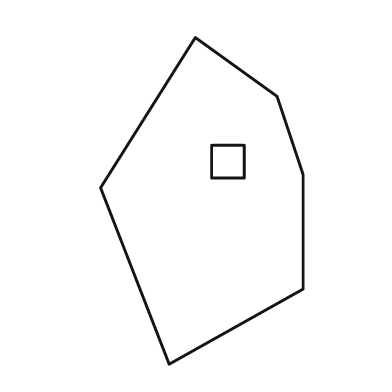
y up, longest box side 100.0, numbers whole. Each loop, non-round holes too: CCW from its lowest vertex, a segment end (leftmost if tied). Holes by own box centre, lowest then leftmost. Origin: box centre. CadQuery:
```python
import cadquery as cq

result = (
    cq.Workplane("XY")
    .moveTo(-10.0, -50.0)
    .lineTo(31.0, -27.0)
    .lineTo(31.0, 8.0)
    .lineTo(23.0, 32.0)
    .lineTo(-2.0, 50.0)
    .lineTo(-31.0, 4.0)
    .close()
    .moveTo(3.0, 7.0)
    .lineTo(13.0, 7.0)
    .lineTo(13.0, 17.0)
    .lineTo(3.0, 17.0)
    .close()
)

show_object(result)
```